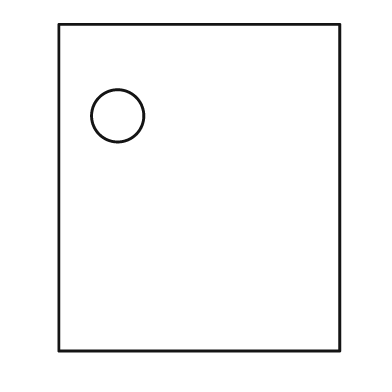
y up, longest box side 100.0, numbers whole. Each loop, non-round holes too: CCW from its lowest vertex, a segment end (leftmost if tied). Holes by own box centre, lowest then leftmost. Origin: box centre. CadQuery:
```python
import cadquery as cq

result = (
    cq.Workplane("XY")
    .moveTo(-43.0, -50.0)
    .lineTo(43.0, -50.0)
    .lineTo(43.0, 50.0)
    .lineTo(-43.0, 50.0)
    .close()
    .moveTo(-25.0, 22.0)
    .circle(8.0)
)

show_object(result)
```